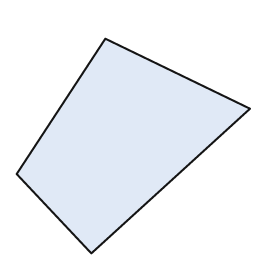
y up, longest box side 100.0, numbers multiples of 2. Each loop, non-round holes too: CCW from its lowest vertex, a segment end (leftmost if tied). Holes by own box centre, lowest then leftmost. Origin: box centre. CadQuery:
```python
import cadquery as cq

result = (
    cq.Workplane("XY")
    .moveTo(-18.0, -46.0)
    .lineTo(50.0, 16.0)
    .lineTo(-12.0, 46.0)
    .lineTo(-50.0, -12.0)
    .close()
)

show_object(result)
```